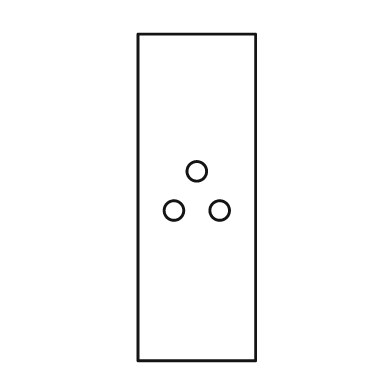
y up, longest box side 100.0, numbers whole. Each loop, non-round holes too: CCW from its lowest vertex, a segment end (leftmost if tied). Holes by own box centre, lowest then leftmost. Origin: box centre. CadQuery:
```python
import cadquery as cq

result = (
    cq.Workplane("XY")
    .moveTo(-18.0, -50.0)
    .lineTo(18.0, -50.0)
    .lineTo(18.0, 50.0)
    .lineTo(-18.0, 50.0)
    .close()
    .moveTo(-7.0, -4.0)
    .circle(3.0)
    .moveTo(7.0, -4.0)
    .circle(3.0)
    .moveTo(0.0, 8.0)
    .circle(3.0)
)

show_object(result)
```